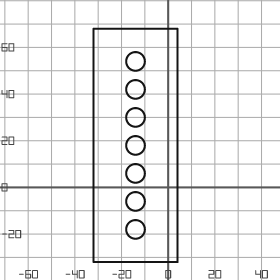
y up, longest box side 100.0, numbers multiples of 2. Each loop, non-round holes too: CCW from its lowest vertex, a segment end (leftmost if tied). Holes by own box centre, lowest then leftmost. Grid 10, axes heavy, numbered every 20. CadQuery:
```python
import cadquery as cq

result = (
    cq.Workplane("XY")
    .moveTo(-32.0, -32.0)
    .lineTo(4.0, -32.0)
    .lineTo(4.0, 68.0)
    .lineTo(-32.0, 68.0)
    .close()
    .moveTo(-14.0, -18.0)
    .circle(4.0)
    .moveTo(-14.0, -6.0)
    .circle(4.0)
    .moveTo(-14.0, 6.0)
    .circle(4.0)
    .moveTo(-14.0, 18.0)
    .circle(4.0)
    .moveTo(-14.0, 30.0)
    .circle(4.0)
    .moveTo(-14.0, 42.0)
    .circle(4.0)
    .moveTo(-14.0, 54.0)
    .circle(4.0)
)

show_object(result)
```